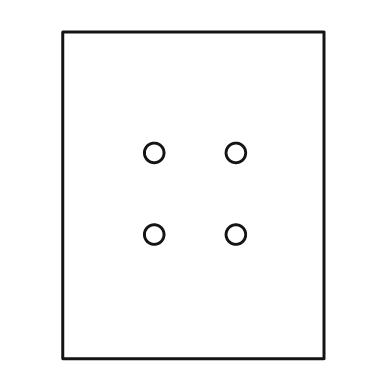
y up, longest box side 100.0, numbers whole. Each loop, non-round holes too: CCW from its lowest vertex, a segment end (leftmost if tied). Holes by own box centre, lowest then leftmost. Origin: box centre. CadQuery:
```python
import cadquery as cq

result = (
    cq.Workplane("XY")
    .moveTo(-40.0, -50.0)
    .lineTo(40.0, -50.0)
    .lineTo(40.0, 50.0)
    .lineTo(-40.0, 50.0)
    .close()
    .moveTo(-12.0, -12.0)
    .circle(3.0)
    .moveTo(13.0, -12.0)
    .circle(3.0)
    .moveTo(-12.0, 13.0)
    .circle(3.0)
    .moveTo(13.0, 13.0)
    .circle(3.0)
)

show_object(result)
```